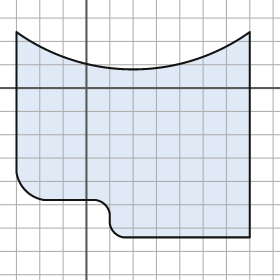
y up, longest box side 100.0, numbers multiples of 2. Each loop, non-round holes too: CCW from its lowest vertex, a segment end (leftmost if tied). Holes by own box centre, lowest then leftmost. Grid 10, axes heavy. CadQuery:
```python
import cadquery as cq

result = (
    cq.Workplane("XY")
    .moveTo(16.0, -64.0)
    .lineTo(70.0, -64.0)
    .lineTo(70.0, 24.0)
    .threePointArc((20.0, 8.0), (-30.0, 24.0))
    .lineTo(-30.0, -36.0)
    .threePointArc((-26.0, -44.0), (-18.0, -48.0))
    .lineTo(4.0, -48.0)
    .threePointArc((8.0, -50.0), (10.0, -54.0))
    .lineTo(10.0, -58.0)
    .threePointArc((12.0, -62.0), (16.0, -64.0))
    .close()
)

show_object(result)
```